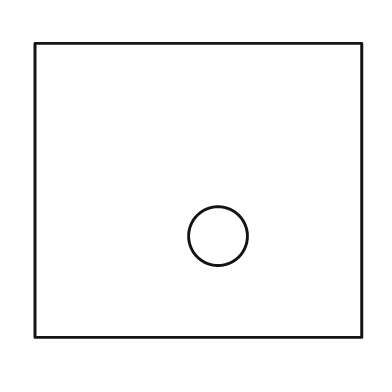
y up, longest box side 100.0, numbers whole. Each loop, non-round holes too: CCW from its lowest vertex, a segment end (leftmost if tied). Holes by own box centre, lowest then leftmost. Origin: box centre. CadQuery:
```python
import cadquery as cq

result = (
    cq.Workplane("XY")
    .moveTo(-50.0, -45.0)
    .lineTo(50.0, -45.0)
    .lineTo(50.0, 45.0)
    .lineTo(-50.0, 45.0)
    .close()
    .moveTo(6.0, -14.0)
    .circle(9.0)
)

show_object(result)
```